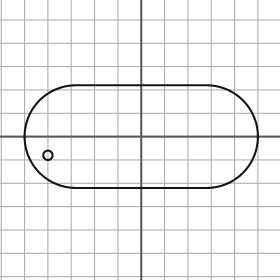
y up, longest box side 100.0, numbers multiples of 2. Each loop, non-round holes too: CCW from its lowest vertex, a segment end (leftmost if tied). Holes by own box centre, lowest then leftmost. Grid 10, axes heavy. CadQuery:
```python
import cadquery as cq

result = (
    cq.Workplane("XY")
    .moveTo(-28.0, -22.0)
    .lineTo(28.0, -22.0)
    .threePointArc((50.0, 0.0), (28.0, 22.0))
    .lineTo(-28.0, 22.0)
    .threePointArc((-50.0, 0.0), (-28.0, -22.0))
    .close()
    .moveTo(-40.0, -8.0)
    .circle(2.0)
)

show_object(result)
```